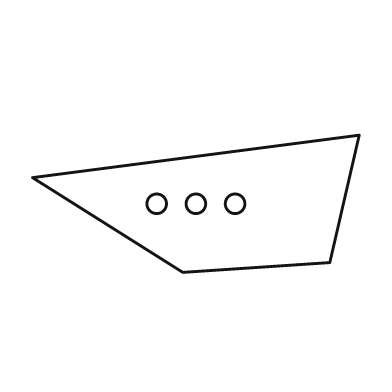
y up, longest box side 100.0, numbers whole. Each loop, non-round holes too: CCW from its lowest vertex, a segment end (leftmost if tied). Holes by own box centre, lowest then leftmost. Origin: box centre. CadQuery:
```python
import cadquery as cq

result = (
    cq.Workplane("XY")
    .moveTo(-4.0, -21.0)
    .lineTo(41.0, -18.0)
    .lineTo(50.0, 21.0)
    .lineTo(-50.0, 8.0)
    .close()
    .moveTo(-12.0, 0.0)
    .circle(3.0)
    .moveTo(0.0, 0.0)
    .circle(3.0)
    .moveTo(12.0, 0.0)
    .circle(3.0)
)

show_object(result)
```